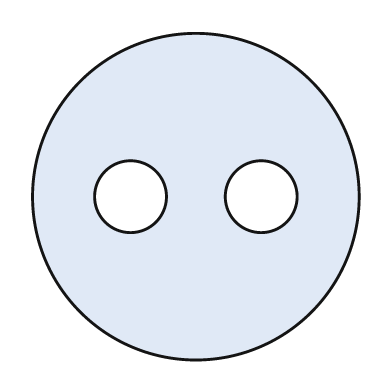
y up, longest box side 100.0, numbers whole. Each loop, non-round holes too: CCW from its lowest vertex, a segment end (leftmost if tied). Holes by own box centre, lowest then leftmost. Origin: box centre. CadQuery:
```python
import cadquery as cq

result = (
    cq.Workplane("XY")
    .moveTo(0.0, 0.0)
    .circle(50.0)
    .moveTo(-20.0, 0.0)
    .circle(11.0)
    .moveTo(20.0, 0.0)
    .circle(11.0)
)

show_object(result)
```